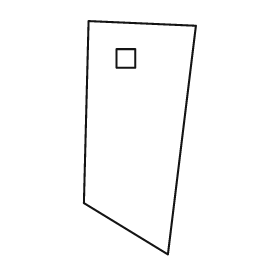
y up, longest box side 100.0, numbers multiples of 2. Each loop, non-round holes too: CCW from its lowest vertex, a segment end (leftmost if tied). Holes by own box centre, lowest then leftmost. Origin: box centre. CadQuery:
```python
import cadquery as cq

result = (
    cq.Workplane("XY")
    .moveTo(12.0, -50.0)
    .lineTo(24.0, 48.0)
    .lineTo(-22.0, 50.0)
    .lineTo(-24.0, -28.0)
    .close()
    .moveTo(-10.0, 30.0)
    .lineTo(-2.0, 30.0)
    .lineTo(-2.0, 38.0)
    .lineTo(-10.0, 38.0)
    .close()
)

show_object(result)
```